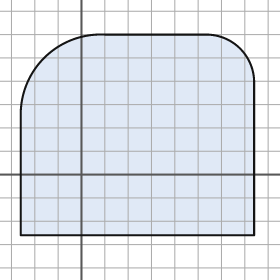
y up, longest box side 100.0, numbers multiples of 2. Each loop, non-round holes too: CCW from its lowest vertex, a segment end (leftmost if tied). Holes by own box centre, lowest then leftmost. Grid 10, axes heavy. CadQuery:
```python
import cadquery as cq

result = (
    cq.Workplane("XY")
    .moveTo(-26.0, -26.0)
    .lineTo(74.0, -26.0)
    .lineTo(74.0, 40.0)
    .threePointArc((68.0, 54.0), (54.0, 60.0))
    .lineTo(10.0, 60.0)
    .threePointArc((-16.0, 50.0), (-26.0, 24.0))
    .close()
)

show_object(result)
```